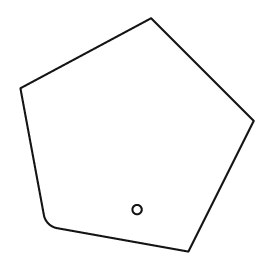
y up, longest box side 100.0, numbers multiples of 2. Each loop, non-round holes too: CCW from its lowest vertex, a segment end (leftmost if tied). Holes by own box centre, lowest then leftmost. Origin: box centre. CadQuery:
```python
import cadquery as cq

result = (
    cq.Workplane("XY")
    .moveTo(22.0, -50.0)
    .lineTo(50.0, 6.0)
    .lineTo(6.0, 50.0)
    .lineTo(-50.0, 20.0)
    .lineTo(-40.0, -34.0)
    .threePointArc((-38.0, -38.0), (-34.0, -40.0))
    .close()
    .moveTo(0.0, -32.0)
    .circle(2.0)
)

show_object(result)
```